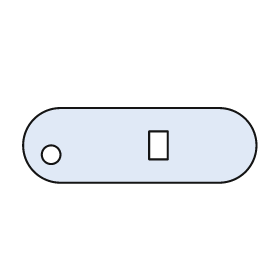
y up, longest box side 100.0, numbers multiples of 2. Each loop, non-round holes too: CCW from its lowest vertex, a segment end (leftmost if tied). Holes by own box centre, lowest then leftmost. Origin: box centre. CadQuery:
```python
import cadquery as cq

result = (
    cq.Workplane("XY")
    .moveTo(-34.0, -16.0)
    .lineTo(34.0, -16.0)
    .threePointArc((50.0, 0.0), (34.0, 16.0))
    .lineTo(-34.0, 16.0)
    .threePointArc((-50.0, 0.0), (-34.0, -16.0))
    .close()
    .moveTo(-38.0, -4.0)
    .circle(4.0)
    .moveTo(4.0, -6.0)
    .lineTo(12.0, -6.0)
    .lineTo(12.0, 6.0)
    .lineTo(4.0, 6.0)
    .close()
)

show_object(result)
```